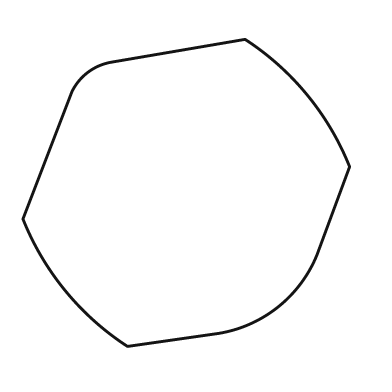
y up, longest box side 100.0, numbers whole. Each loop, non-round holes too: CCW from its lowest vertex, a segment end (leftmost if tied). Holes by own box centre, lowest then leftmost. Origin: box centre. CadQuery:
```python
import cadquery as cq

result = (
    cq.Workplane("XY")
    .moveTo(-18.0, -47.0)
    .lineTo(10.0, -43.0)
    .threePointArc((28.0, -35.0), (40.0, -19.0))
    .lineTo(50.0, 8.0)
    .threePointArc((37.0, 30.0), (18.0, 47.0))
    .lineTo(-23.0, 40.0)
    .threePointArc((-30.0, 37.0), (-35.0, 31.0))
    .lineTo(-50.0, -8.0)
    .threePointArc((-37.0, -30.0), (-18.0, -47.0))
    .close()
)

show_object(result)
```